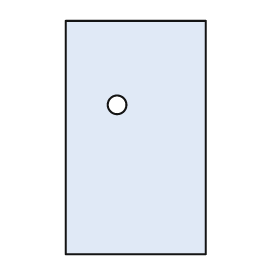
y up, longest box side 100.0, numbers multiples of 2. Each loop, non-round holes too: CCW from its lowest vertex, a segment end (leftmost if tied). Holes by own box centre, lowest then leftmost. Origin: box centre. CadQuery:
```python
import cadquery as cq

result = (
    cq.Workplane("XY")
    .moveTo(-30.0, -50.0)
    .lineTo(30.0, -50.0)
    .lineTo(30.0, 50.0)
    .lineTo(-30.0, 50.0)
    .close()
    .moveTo(-8.0, 14.0)
    .circle(4.0)
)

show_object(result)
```